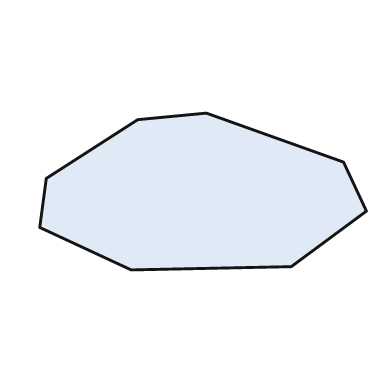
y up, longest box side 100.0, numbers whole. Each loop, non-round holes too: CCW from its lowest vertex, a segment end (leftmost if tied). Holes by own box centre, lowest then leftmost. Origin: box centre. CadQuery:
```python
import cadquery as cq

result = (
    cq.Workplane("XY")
    .moveTo(-22.0, -24.0)
    .lineTo(27.0, -23.0)
    .lineTo(50.0, -6.0)
    .lineTo(43.0, 9.0)
    .lineTo(1.0, 24.0)
    .lineTo(-20.0, 22.0)
    .lineTo(-48.0, 4.0)
    .lineTo(-50.0, -11.0)
    .close()
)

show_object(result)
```